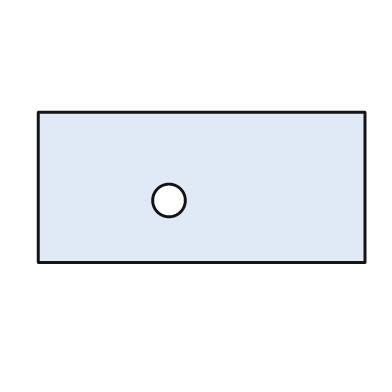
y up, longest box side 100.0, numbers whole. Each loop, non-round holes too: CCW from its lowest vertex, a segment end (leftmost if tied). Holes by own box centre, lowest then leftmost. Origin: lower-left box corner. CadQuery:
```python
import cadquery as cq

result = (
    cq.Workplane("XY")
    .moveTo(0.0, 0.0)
    .lineTo(100.0, 0.0)
    .lineTo(100.0, 46.0)
    .lineTo(0.0, 46.0)
    .close()
    .moveTo(40.0, 19.0)
    .circle(5.0)
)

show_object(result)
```